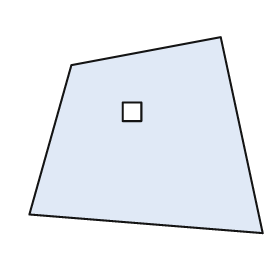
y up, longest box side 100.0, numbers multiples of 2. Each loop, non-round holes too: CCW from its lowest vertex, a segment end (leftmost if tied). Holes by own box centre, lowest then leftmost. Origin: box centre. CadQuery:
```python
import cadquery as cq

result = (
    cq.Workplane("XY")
    .moveTo(50.0, -42.0)
    .lineTo(32.0, 42.0)
    .lineTo(-32.0, 30.0)
    .lineTo(-50.0, -34.0)
    .close()
    .moveTo(-10.0, 6.0)
    .lineTo(-2.0, 6.0)
    .lineTo(-2.0, 14.0)
    .lineTo(-10.0, 14.0)
    .close()
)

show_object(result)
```